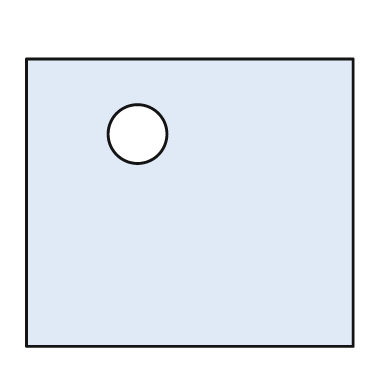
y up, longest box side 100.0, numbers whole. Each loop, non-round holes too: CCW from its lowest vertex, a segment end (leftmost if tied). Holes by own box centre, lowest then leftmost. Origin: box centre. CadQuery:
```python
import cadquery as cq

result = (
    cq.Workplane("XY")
    .moveTo(-50.0, -44.0)
    .lineTo(50.0, -44.0)
    .lineTo(50.0, 44.0)
    .lineTo(-50.0, 44.0)
    .close()
    .moveTo(-16.0, 21.0)
    .circle(9.0)
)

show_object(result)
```